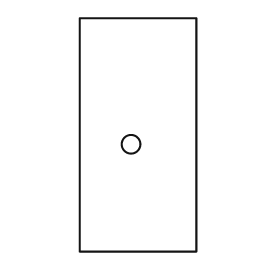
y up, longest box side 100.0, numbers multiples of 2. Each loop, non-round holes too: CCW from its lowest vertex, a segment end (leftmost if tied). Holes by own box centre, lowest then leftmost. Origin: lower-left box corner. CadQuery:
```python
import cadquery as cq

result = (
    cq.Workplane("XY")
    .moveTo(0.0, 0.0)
    .lineTo(50.0, 0.0)
    .lineTo(50.0, 100.0)
    .lineTo(0.0, 100.0)
    .close()
    .moveTo(22.0, 46.0)
    .circle(4.0)
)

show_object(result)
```